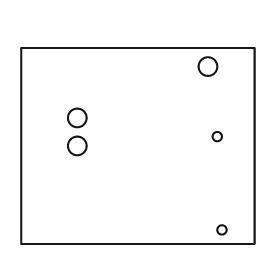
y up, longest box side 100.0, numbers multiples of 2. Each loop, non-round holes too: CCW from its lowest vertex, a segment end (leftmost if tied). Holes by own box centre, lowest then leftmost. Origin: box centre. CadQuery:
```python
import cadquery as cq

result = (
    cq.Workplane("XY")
    .moveTo(-50.0, -42.0)
    .lineTo(50.0, -42.0)
    .lineTo(50.0, 42.0)
    .lineTo(-50.0, 42.0)
    .close()
    .moveTo(36.0, -36.0)
    .circle(2.0)
    .moveTo(-26.0, 0.0)
    .circle(4.0)
    .moveTo(34.0, 4.0)
    .circle(2.0)
    .moveTo(-26.0, 12.0)
    .circle(4.0)
    .moveTo(30.0, 34.0)
    .circle(4.0)
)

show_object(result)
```